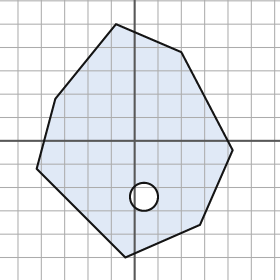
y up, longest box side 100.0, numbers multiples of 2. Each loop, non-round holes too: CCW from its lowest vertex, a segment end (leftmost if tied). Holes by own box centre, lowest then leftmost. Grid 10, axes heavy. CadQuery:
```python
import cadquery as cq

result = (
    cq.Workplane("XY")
    .moveTo(-4.0, -50.0)
    .lineTo(28.0, -36.0)
    .lineTo(42.0, -4.0)
    .lineTo(20.0, 38.0)
    .lineTo(-8.0, 50.0)
    .lineTo(-34.0, 18.0)
    .lineTo(-42.0, -12.0)
    .close()
    .moveTo(4.0, -24.0)
    .circle(6.0)
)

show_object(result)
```